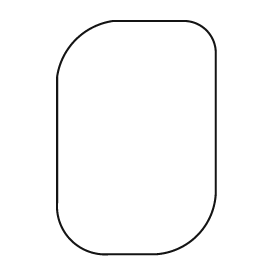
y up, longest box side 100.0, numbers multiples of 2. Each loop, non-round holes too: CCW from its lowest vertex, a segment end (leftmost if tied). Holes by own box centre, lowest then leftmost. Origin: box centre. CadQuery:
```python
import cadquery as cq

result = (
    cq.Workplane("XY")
    .moveTo(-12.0, -50.0)
    .lineTo(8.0, -50.0)
    .threePointArc((26.0, -42.0), (34.0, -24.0))
    .lineTo(34.0, 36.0)
    .threePointArc((30.0, 46.0), (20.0, 50.0))
    .lineTo(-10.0, 50.0)
    .threePointArc((-26.0, 42.0), (-34.0, 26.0))
    .lineTo(-34.0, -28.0)
    .threePointArc((-28.0, -44.0), (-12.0, -50.0))
    .close()
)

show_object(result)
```